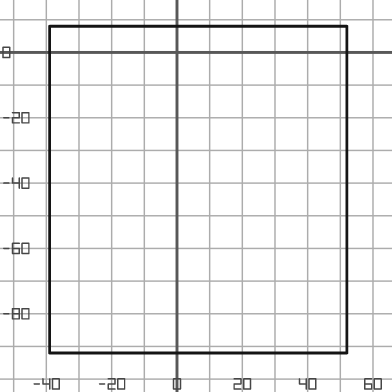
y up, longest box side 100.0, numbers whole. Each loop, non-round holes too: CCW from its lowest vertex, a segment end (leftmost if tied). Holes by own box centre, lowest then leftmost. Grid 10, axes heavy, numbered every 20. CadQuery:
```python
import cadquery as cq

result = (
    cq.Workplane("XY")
    .moveTo(-39.0, -92.0)
    .lineTo(52.0, -92.0)
    .lineTo(52.0, 8.0)
    .lineTo(-39.0, 8.0)
    .close()
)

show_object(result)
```